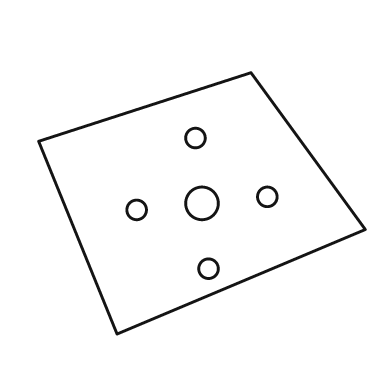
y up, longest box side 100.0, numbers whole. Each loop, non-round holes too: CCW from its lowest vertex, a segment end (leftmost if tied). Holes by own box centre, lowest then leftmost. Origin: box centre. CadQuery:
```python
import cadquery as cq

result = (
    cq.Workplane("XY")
    .moveTo(-26.0, -40.0)
    .lineTo(50.0, -8.0)
    .lineTo(15.0, 40.0)
    .lineTo(-50.0, 19.0)
    .close()
    .moveTo(2.0, -20.0)
    .circle(3.0)
    .moveTo(-20.0, -2.0)
    .circle(3.0)
    .moveTo(0.0, 0.0)
    .circle(5.0)
    .moveTo(20.0, 2.0)
    .circle(3.0)
    .moveTo(-2.0, 20.0)
    .circle(3.0)
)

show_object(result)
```